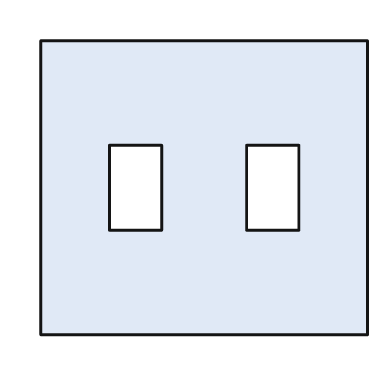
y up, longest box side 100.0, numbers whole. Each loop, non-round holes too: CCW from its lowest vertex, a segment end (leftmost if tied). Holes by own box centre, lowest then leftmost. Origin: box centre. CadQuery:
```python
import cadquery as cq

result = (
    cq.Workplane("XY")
    .moveTo(-50.0, -45.0)
    .lineTo(50.0, -45.0)
    .lineTo(50.0, 45.0)
    .lineTo(-50.0, 45.0)
    .close()
    .moveTo(-29.0, -13.0)
    .lineTo(-13.0, -13.0)
    .lineTo(-13.0, 13.0)
    .lineTo(-29.0, 13.0)
    .close()
    .moveTo(13.0, -13.0)
    .lineTo(29.0, -13.0)
    .lineTo(29.0, 13.0)
    .lineTo(13.0, 13.0)
    .close()
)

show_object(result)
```